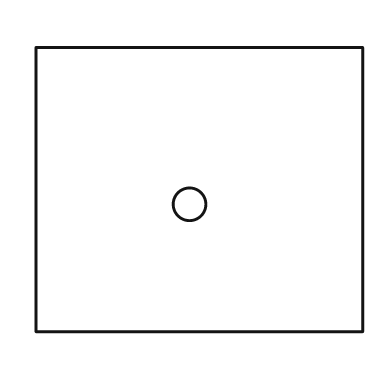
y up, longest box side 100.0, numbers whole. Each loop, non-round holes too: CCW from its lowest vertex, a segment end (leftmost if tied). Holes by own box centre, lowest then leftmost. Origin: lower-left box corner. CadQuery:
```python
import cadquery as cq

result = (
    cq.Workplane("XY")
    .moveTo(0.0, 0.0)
    .lineTo(100.0, 0.0)
    .lineTo(100.0, 87.0)
    .lineTo(0.0, 87.0)
    .close()
    .moveTo(47.0, 39.0)
    .circle(5.0)
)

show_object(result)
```